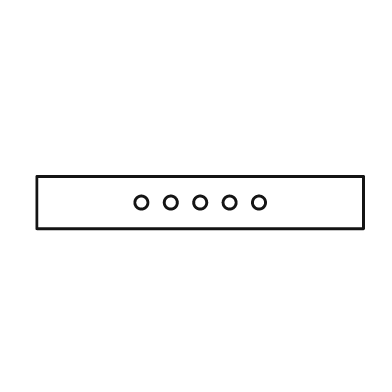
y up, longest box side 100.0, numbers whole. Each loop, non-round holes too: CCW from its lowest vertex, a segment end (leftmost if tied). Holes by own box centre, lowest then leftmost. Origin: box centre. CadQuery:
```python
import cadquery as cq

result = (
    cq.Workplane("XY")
    .moveTo(-50.0, -8.0)
    .lineTo(50.0, -8.0)
    .lineTo(50.0, 8.0)
    .lineTo(-50.0, 8.0)
    .close()
    .moveTo(-18.0, 0.0)
    .circle(2.0)
    .moveTo(-9.0, 0.0)
    .circle(2.0)
    .moveTo(0.0, 0.0)
    .circle(2.0)
    .moveTo(9.0, 0.0)
    .circle(2.0)
    .moveTo(18.0, 0.0)
    .circle(2.0)
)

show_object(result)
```